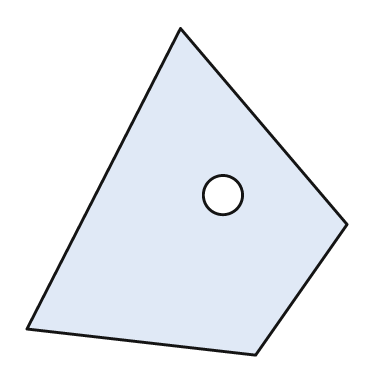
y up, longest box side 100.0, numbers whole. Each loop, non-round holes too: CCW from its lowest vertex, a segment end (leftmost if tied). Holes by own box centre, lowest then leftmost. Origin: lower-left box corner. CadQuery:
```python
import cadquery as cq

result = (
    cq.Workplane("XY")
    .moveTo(70.0, 0.0)
    .lineTo(98.0, 40.0)
    .lineTo(47.0, 100.0)
    .lineTo(0.0, 8.0)
    .close()
    .moveTo(60.0, 49.0)
    .circle(6.0)
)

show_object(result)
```